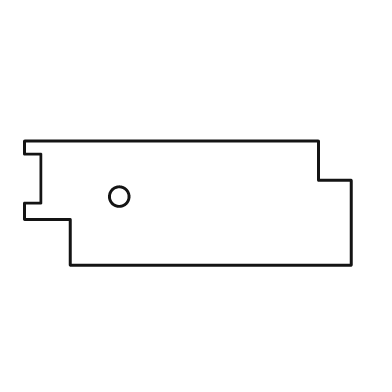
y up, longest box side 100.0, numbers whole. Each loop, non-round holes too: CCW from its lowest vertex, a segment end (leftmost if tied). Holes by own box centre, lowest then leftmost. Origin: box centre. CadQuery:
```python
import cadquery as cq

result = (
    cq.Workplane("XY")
    .moveTo(-36.0, -19.0)
    .lineTo(50.0, -19.0)
    .lineTo(50.0, 7.0)
    .lineTo(40.0, 7.0)
    .lineTo(40.0, 19.0)
    .lineTo(-50.0, 19.0)
    .lineTo(-50.0, 15.0)
    .lineTo(-45.0, 15.0)
    .lineTo(-45.0, 0.0)
    .lineTo(-50.0, 0.0)
    .lineTo(-50.0, -5.0)
    .lineTo(-36.0, -5.0)
    .close()
    .moveTo(-21.0, 2.0)
    .circle(3.0)
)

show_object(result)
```